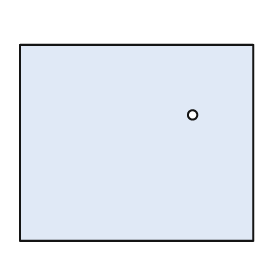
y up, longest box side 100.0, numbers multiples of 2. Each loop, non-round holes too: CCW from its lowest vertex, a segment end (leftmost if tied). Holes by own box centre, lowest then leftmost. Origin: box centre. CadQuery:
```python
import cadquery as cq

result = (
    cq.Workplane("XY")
    .moveTo(-50.0, -42.0)
    .lineTo(50.0, -42.0)
    .lineTo(50.0, 42.0)
    .lineTo(-50.0, 42.0)
    .close()
    .moveTo(24.0, 12.0)
    .circle(2.0)
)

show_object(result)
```